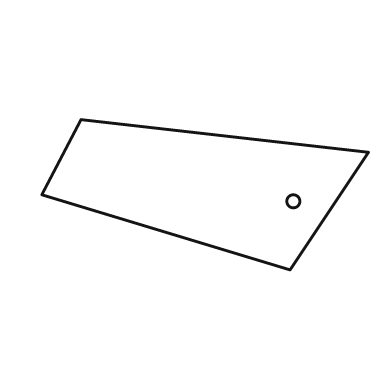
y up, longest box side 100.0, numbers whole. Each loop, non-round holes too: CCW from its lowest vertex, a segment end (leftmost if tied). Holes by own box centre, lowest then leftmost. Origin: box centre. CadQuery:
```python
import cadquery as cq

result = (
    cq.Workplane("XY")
    .moveTo(26.0, -23.0)
    .lineTo(50.0, 13.0)
    .lineTo(-38.0, 23.0)
    .lineTo(-50.0, 0.0)
    .close()
    .moveTo(27.0, -2.0)
    .circle(2.0)
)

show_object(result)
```